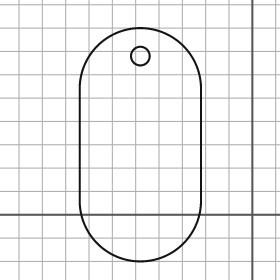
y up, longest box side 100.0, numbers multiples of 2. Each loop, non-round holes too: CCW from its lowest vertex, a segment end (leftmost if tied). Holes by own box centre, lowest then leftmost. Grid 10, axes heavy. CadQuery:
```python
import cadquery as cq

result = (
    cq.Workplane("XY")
    .moveTo(-74.0, 6.0)
    .threePointArc((-48.0, -20.0), (-22.0, 6.0))
    .lineTo(-22.0, 54.0)
    .threePointArc((-48.0, 80.0), (-74.0, 54.0))
    .close()
    .moveTo(-48.0, 68.0)
    .circle(4.0)
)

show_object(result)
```